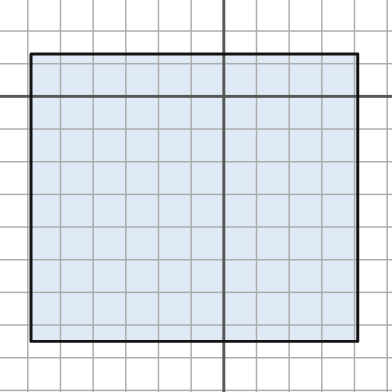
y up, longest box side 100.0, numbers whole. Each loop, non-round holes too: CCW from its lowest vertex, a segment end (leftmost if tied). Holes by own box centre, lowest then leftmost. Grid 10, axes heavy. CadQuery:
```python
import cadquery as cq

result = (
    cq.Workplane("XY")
    .moveTo(-59.0, -75.0)
    .lineTo(41.0, -75.0)
    .lineTo(41.0, 13.0)
    .lineTo(-59.0, 13.0)
    .close()
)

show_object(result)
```